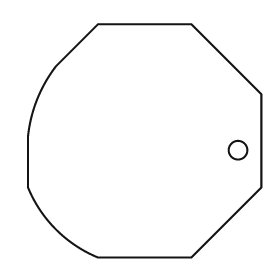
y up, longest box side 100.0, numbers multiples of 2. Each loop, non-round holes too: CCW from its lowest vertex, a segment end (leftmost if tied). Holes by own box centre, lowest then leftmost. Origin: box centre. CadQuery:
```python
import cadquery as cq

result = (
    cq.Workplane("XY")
    .moveTo(-20.0, -50.0)
    .lineTo(20.0, -50.0)
    .lineTo(50.0, -20.0)
    .lineTo(50.0, 20.0)
    .lineTo(20.0, 50.0)
    .lineTo(-20.0, 50.0)
    .lineTo(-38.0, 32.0)
    .threePointArc((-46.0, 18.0), (-50.0, 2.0))
    .lineTo(-50.0, -20.0)
    .threePointArc((-38.0, -38.0), (-20.0, -50.0))
    .close()
    .moveTo(40.0, -4.0)
    .circle(4.0)
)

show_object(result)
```